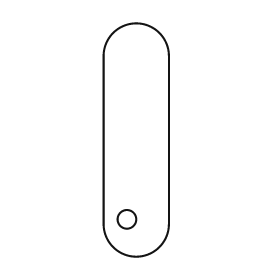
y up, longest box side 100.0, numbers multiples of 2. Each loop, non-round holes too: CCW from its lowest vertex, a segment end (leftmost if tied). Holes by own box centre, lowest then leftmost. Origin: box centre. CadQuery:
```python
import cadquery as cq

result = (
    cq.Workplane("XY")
    .moveTo(-14.0, -36.0)
    .threePointArc((0.0, -50.0), (14.0, -36.0))
    .lineTo(14.0, 36.0)
    .threePointArc((0.0, 50.0), (-14.0, 36.0))
    .close()
    .moveTo(-4.0, -34.0)
    .circle(4.0)
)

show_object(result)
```